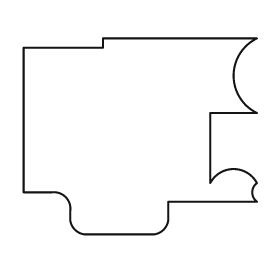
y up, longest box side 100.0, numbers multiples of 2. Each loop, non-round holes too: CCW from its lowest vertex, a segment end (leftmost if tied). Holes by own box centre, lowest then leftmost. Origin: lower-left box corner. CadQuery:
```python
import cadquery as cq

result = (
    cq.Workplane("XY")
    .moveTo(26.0, 0.0)
    .lineTo(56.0, 0.0)
    .threePointArc((60.0, 2.0), (62.0, 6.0))
    .lineTo(62.0, 14.0)
    .lineTo(100.0, 14.0)
    .threePointArc((98.0, 18.0), (100.0, 22.0))
    .threePointArc((90.0, 28.0), (80.0, 22.0))
    .lineTo(80.0, 52.0)
    .lineTo(100.0, 52.0)
    .threePointArc((90.0, 68.0), (100.0, 84.0))
    .lineTo(34.0, 84.0)
    .lineTo(34.0, 80.0)
    .lineTo(0.0, 80.0)
    .lineTo(0.0, 18.0)
    .lineTo(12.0, 18.0)
    .threePointArc((18.0, 16.0), (20.0, 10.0))
    .lineTo(20.0, 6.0)
    .threePointArc((22.0, 2.0), (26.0, 0.0))
    .close()
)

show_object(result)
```